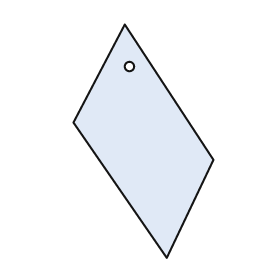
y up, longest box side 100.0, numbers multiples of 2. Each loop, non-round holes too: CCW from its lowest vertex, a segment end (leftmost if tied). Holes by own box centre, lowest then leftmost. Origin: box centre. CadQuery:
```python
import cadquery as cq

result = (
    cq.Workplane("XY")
    .moveTo(10.0, -50.0)
    .lineTo(30.0, -8.0)
    .lineTo(-8.0, 50.0)
    .lineTo(-30.0, 8.0)
    .close()
    .moveTo(-6.0, 32.0)
    .circle(2.0)
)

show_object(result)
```